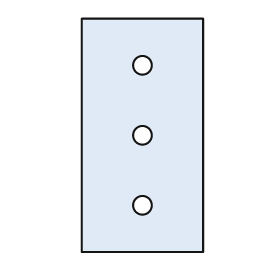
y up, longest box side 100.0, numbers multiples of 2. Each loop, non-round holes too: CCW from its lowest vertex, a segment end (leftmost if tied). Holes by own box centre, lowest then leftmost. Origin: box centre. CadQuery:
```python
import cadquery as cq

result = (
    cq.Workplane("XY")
    .moveTo(-26.0, -50.0)
    .lineTo(26.0, -50.0)
    .lineTo(26.0, 50.0)
    .lineTo(-26.0, 50.0)
    .close()
    .moveTo(0.0, -30.0)
    .circle(4.0)
    .moveTo(0.0, 0.0)
    .circle(4.0)
    .moveTo(0.0, 30.0)
    .circle(4.0)
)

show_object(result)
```